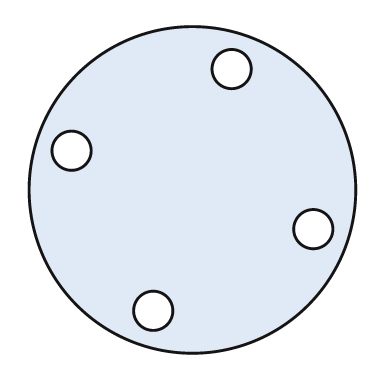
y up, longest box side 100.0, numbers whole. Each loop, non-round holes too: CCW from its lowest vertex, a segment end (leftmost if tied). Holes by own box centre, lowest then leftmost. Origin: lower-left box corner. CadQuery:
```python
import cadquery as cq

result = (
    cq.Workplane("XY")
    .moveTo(50.0, 50.0)
    .circle(50.0)
    .moveTo(38.0, 13.0)
    .circle(6.0)
    .moveTo(87.0, 38.0)
    .circle(6.0)
    .moveTo(13.0, 62.0)
    .circle(6.0)
    .moveTo(62.0, 87.0)
    .circle(6.0)
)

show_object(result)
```